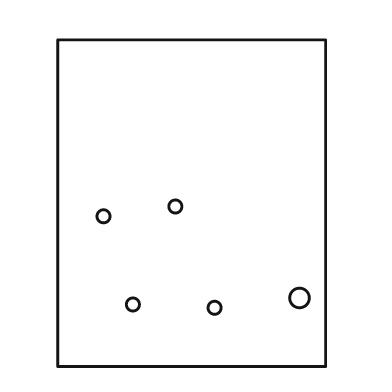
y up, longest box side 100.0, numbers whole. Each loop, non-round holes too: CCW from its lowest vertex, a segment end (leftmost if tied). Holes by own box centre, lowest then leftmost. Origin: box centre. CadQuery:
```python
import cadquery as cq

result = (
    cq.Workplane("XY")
    .moveTo(-41.0, -50.0)
    .lineTo(41.0, -50.0)
    .lineTo(41.0, 50.0)
    .lineTo(-41.0, 50.0)
    .close()
    .moveTo(7.0, -32.0)
    .circle(2.0)
    .moveTo(-18.0, -31.0)
    .circle(2.0)
    .moveTo(33.0, -29.0)
    .circle(3.0)
    .moveTo(-27.0, -4.0)
    .circle(2.0)
    .moveTo(-5.0, -1.0)
    .circle(2.0)
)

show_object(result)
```